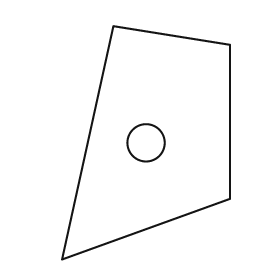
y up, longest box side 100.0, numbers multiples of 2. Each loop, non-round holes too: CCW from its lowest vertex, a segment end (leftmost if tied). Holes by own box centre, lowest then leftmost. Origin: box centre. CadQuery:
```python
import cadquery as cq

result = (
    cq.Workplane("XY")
    .moveTo(-36.0, -50.0)
    .lineTo(36.0, -24.0)
    .lineTo(36.0, 42.0)
    .lineTo(-14.0, 50.0)
    .close()
    .moveTo(0.0, 0.0)
    .circle(8.0)
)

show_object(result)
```